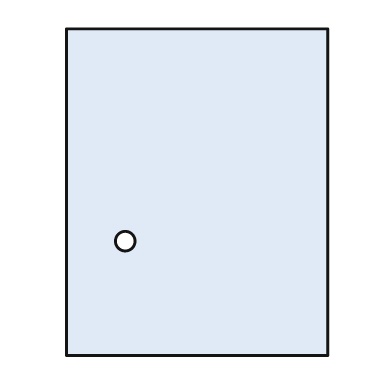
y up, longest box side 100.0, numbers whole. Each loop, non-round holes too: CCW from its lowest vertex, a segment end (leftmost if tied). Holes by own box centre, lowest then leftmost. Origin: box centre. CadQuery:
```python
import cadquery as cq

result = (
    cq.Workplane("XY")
    .moveTo(-40.0, -50.0)
    .lineTo(40.0, -50.0)
    .lineTo(40.0, 50.0)
    .lineTo(-40.0, 50.0)
    .close()
    .moveTo(-22.0, -15.0)
    .circle(3.0)
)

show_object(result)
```